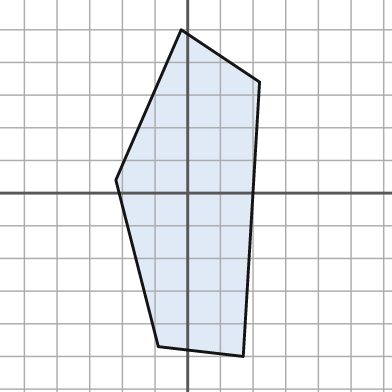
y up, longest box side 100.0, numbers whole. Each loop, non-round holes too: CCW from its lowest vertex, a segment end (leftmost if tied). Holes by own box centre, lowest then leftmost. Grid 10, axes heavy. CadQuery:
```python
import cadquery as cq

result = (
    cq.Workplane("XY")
    .moveTo(17.0, -50.0)
    .lineTo(22.0, 34.0)
    .lineTo(-2.0, 50.0)
    .lineTo(-22.0, 4.0)
    .lineTo(-9.0, -47.0)
    .close()
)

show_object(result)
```